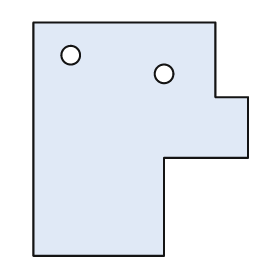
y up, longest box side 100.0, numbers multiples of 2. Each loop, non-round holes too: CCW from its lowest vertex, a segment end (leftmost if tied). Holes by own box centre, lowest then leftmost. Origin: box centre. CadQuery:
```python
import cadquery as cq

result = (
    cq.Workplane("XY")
    .moveTo(-46.0, -50.0)
    .lineTo(10.0, -50.0)
    .lineTo(10.0, -8.0)
    .lineTo(46.0, -8.0)
    .lineTo(46.0, 18.0)
    .lineTo(32.0, 18.0)
    .lineTo(32.0, 50.0)
    .lineTo(-46.0, 50.0)
    .close()
    .moveTo(10.0, 28.0)
    .circle(4.0)
    .moveTo(-30.0, 36.0)
    .circle(4.0)
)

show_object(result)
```